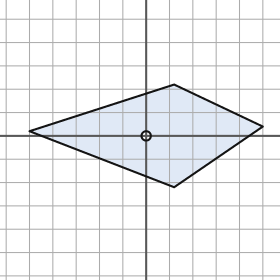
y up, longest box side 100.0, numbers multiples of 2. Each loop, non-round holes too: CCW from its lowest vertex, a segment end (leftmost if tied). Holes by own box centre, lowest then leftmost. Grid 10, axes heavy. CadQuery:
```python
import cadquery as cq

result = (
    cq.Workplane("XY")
    .moveTo(12.0, -22.0)
    .lineTo(50.0, 4.0)
    .lineTo(12.0, 22.0)
    .lineTo(-50.0, 2.0)
    .close()
    .moveTo(0.0, 0.0)
    .circle(2.0)
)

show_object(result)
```